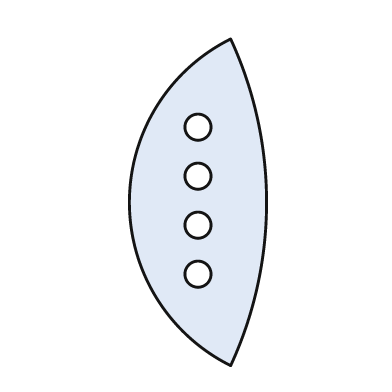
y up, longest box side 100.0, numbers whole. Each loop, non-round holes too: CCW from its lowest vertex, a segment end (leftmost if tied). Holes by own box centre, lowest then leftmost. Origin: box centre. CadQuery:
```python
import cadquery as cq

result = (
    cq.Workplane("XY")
    .moveTo(10.0, -50.0)
    .threePointArc((21.0, 0.0), (10.0, 50.0))
    .threePointArc((-21.0, 0.0), (10.0, -50.0))
    .close()
    .moveTo(0.0, -22.0)
    .circle(4.0)
    .moveTo(0.0, -7.0)
    .circle(4.0)
    .moveTo(0.0, 8.0)
    .circle(4.0)
    .moveTo(0.0, 23.0)
    .circle(4.0)
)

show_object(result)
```